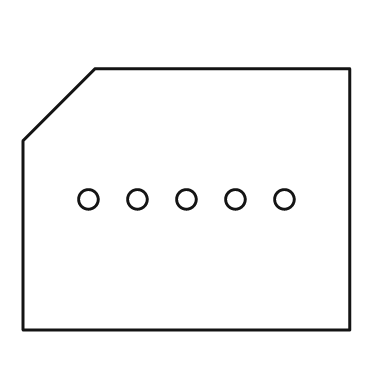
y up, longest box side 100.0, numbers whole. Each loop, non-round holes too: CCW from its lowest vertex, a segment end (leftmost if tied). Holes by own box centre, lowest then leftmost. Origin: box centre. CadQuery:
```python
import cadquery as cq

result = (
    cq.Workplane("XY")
    .moveTo(-50.0, -40.0)
    .lineTo(50.0, -40.0)
    .lineTo(50.0, 40.0)
    .lineTo(-28.0, 40.0)
    .lineTo(-50.0, 18.0)
    .close()
    .moveTo(-30.0, 0.0)
    .circle(3.0)
    .moveTo(-15.0, 0.0)
    .circle(3.0)
    .moveTo(0.0, 0.0)
    .circle(3.0)
    .moveTo(15.0, 0.0)
    .circle(3.0)
    .moveTo(30.0, 0.0)
    .circle(3.0)
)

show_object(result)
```